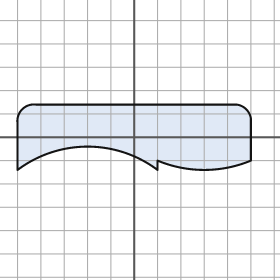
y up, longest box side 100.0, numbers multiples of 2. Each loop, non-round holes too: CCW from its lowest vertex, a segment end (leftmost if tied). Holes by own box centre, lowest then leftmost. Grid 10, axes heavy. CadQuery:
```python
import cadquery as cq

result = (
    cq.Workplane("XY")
    .moveTo(-50.0, -14.0)
    .threePointArc((-20.0, -4.0), (10.0, -14.0))
    .lineTo(10.0, -10.0)
    .threePointArc((30.0, -14.0), (50.0, -10.0))
    .lineTo(50.0, 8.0)
    .threePointArc((48.0, 12.0), (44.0, 14.0))
    .lineTo(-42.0, 14.0)
    .threePointArc((-48.0, 12.0), (-50.0, 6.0))
    .close()
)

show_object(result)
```